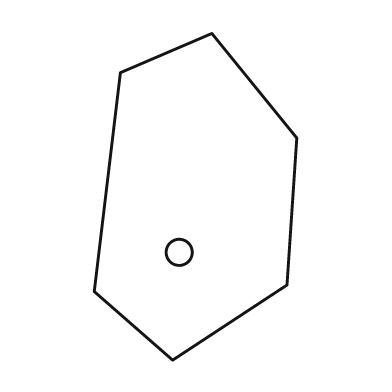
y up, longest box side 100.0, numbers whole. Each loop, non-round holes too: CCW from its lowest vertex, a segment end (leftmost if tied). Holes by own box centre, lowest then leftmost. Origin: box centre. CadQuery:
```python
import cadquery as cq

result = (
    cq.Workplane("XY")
    .moveTo(-7.0, -50.0)
    .lineTo(28.0, -27.0)
    .lineTo(31.0, 18.0)
    .lineTo(5.0, 50.0)
    .lineTo(-23.0, 38.0)
    .lineTo(-31.0, -29.0)
    .close()
    .moveTo(-5.0, -17.0)
    .circle(4.0)
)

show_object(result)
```